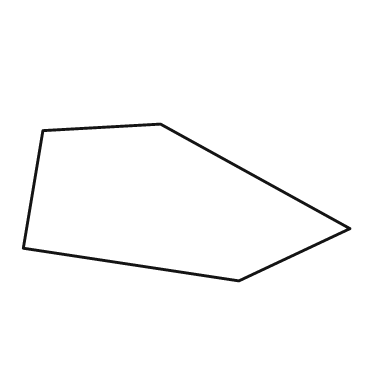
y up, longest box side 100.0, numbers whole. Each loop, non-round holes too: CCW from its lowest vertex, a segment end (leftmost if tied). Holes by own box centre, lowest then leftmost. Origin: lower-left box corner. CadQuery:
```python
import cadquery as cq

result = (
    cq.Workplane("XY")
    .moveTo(66.0, 0.0)
    .lineTo(100.0, 16.0)
    .lineTo(42.0, 48.0)
    .lineTo(6.0, 46.0)
    .lineTo(0.0, 10.0)
    .close()
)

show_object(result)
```